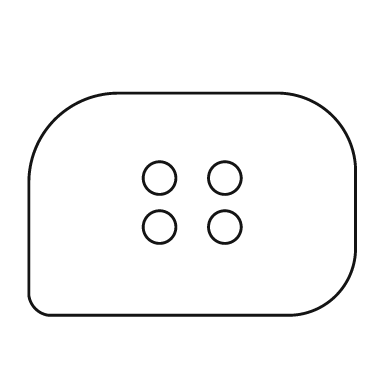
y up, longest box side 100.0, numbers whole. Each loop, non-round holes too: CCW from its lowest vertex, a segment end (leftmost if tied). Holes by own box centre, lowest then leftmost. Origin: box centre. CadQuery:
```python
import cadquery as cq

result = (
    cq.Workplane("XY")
    .moveTo(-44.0, -34.0)
    .lineTo(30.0, -34.0)
    .threePointArc((44.0, -28.0), (50.0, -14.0))
    .lineTo(50.0, 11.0)
    .threePointArc((43.0, 27.0), (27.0, 34.0))
    .lineTo(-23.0, 34.0)
    .threePointArc((-42.0, 26.0), (-50.0, 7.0))
    .lineTo(-50.0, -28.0)
    .threePointArc((-48.0, -32.0), (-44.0, -34.0))
    .close()
    .moveTo(-10.0, -7.0)
    .circle(5.0)
    .moveTo(10.0, -7.0)
    .circle(5.0)
    .moveTo(-10.0, 8.0)
    .circle(5.0)
    .moveTo(10.0, 8.0)
    .circle(5.0)
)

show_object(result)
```